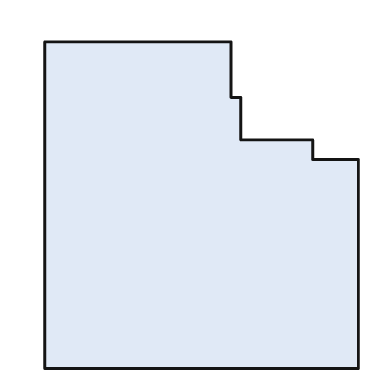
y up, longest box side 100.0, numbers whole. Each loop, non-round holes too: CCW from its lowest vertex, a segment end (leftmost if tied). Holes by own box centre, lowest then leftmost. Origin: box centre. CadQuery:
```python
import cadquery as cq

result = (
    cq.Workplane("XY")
    .moveTo(-48.0, -50.0)
    .lineTo(48.0, -50.0)
    .lineTo(48.0, 14.0)
    .lineTo(34.0, 14.0)
    .lineTo(34.0, 20.0)
    .lineTo(12.0, 20.0)
    .lineTo(12.0, 33.0)
    .lineTo(9.0, 33.0)
    .lineTo(9.0, 50.0)
    .lineTo(-48.0, 50.0)
    .close()
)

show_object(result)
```